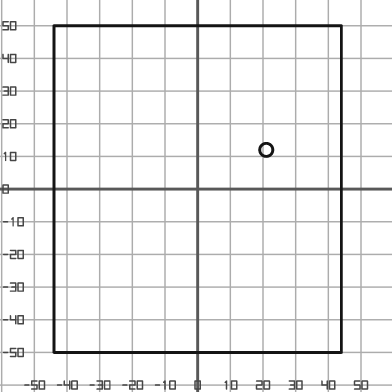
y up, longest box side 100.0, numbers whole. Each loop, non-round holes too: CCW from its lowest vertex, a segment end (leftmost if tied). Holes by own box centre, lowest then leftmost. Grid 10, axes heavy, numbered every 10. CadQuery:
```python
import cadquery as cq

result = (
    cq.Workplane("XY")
    .moveTo(-44.0, -50.0)
    .lineTo(44.0, -50.0)
    .lineTo(44.0, 50.0)
    .lineTo(-44.0, 50.0)
    .close()
    .moveTo(21.0, 12.0)
    .circle(2.0)
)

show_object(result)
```